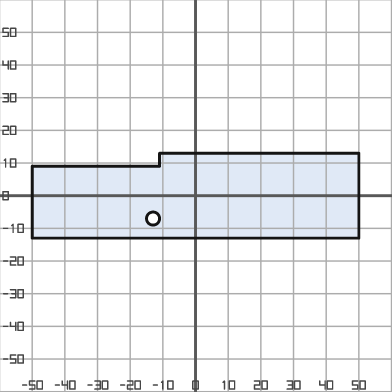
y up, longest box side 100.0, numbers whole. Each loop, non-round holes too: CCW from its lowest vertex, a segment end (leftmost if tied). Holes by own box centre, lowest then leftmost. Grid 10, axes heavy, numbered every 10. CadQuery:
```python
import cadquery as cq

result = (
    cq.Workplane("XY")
    .moveTo(-50.0, -13.0)
    .lineTo(50.0, -13.0)
    .lineTo(50.0, 13.0)
    .lineTo(-11.0, 13.0)
    .lineTo(-11.0, 9.0)
    .lineTo(-50.0, 9.0)
    .close()
    .moveTo(-13.0, -7.0)
    .circle(2.0)
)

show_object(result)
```